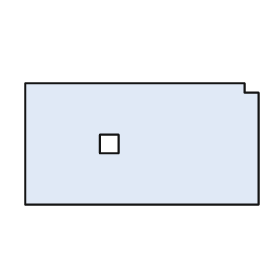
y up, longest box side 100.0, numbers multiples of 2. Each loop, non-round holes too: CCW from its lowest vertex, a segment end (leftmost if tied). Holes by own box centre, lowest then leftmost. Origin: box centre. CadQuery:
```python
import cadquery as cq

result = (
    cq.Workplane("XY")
    .moveTo(-50.0, -26.0)
    .lineTo(50.0, -26.0)
    .lineTo(50.0, 22.0)
    .lineTo(44.0, 22.0)
    .lineTo(44.0, 26.0)
    .lineTo(-50.0, 26.0)
    .close()
    .moveTo(-18.0, -4.0)
    .lineTo(-10.0, -4.0)
    .lineTo(-10.0, 4.0)
    .lineTo(-18.0, 4.0)
    .close()
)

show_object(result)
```